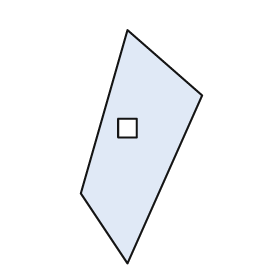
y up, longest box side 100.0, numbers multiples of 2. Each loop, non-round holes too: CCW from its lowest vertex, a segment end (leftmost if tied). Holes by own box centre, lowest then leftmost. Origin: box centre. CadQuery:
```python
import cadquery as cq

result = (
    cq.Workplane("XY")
    .moveTo(-6.0, -50.0)
    .lineTo(26.0, 22.0)
    .lineTo(-6.0, 50.0)
    .lineTo(-26.0, -20.0)
    .close()
    .moveTo(-10.0, 4.0)
    .lineTo(-2.0, 4.0)
    .lineTo(-2.0, 12.0)
    .lineTo(-10.0, 12.0)
    .close()
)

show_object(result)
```